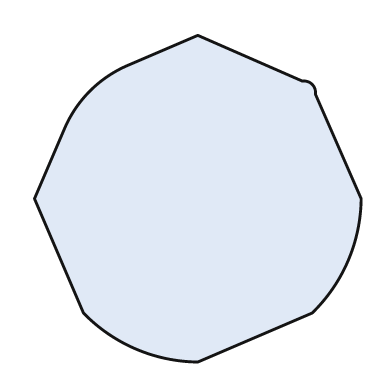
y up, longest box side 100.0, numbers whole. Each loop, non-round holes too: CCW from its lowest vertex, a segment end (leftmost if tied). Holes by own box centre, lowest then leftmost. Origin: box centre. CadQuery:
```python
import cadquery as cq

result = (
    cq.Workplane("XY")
    .moveTo(0.0, -50.0)
    .lineTo(35.0, -35.0)
    .threePointArc((46.0, -19.0), (50.0, 0.0))
    .lineTo(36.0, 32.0)
    .threePointArc((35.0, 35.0), (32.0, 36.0))
    .lineTo(0.0, 50.0)
    .lineTo(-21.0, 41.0)
    .threePointArc((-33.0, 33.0), (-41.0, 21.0))
    .lineTo(-50.0, 0.0)
    .lineTo(-35.0, -35.0)
    .threePointArc((-19.0, -46.0), (0.0, -50.0))
    .close()
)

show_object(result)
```